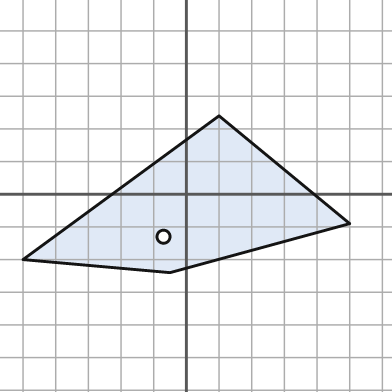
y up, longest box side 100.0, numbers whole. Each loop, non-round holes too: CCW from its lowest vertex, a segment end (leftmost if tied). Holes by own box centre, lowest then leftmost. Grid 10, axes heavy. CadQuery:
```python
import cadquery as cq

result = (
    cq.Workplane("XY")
    .moveTo(-5.0, -24.0)
    .lineTo(50.0, -9.0)
    .lineTo(10.0, 24.0)
    .lineTo(-50.0, -20.0)
    .close()
    .moveTo(-7.0, -13.0)
    .circle(2.0)
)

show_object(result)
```